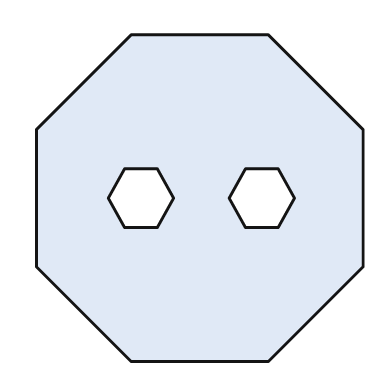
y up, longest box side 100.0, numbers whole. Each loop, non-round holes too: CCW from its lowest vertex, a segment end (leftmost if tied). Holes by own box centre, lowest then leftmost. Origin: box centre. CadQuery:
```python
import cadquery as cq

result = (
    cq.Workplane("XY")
    .moveTo(-21.0, -50.0)
    .lineTo(21.0, -50.0)
    .lineTo(50.0, -21.0)
    .lineTo(50.0, 21.0)
    .lineTo(21.0, 50.0)
    .lineTo(-21.0, 50.0)
    .lineTo(-50.0, 21.0)
    .lineTo(-50.0, -21.0)
    .close()
    .moveTo(-23.0, -9.0)
    .lineTo(-13.0, -9.0)
    .lineTo(-8.0, 0.0)
    .lineTo(-13.0, 9.0)
    .lineTo(-23.0, 9.0)
    .lineTo(-28.0, 0.0)
    .close()
    .moveTo(14.0, -9.0)
    .lineTo(24.0, -9.0)
    .lineTo(29.0, 0.0)
    .lineTo(24.0, 9.0)
    .lineTo(14.0, 9.0)
    .lineTo(9.0, 0.0)
    .close()
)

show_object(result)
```